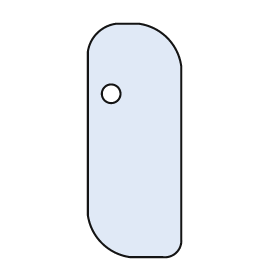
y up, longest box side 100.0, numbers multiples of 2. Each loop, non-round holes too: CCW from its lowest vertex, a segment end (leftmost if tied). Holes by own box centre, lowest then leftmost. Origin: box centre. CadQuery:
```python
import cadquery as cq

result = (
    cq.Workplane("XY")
    .moveTo(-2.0, -50.0)
    .lineTo(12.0, -50.0)
    .threePointArc((18.0, -48.0), (20.0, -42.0))
    .lineTo(20.0, 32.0)
    .threePointArc((14.0, 44.0), (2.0, 50.0))
    .lineTo(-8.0, 50.0)
    .threePointArc((-16.0, 46.0), (-20.0, 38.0))
    .lineTo(-20.0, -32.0)
    .threePointArc((-14.0, -44.0), (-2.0, -50.0))
    .close()
    .moveTo(-10.0, 20.0)
    .circle(4.0)
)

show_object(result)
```